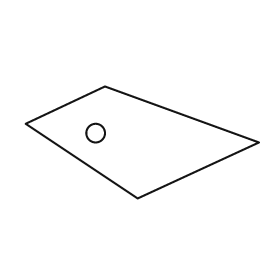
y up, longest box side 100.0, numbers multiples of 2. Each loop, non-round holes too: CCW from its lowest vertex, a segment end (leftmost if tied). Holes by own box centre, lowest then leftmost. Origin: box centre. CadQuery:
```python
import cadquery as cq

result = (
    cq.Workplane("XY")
    .moveTo(-2.0, -24.0)
    .lineTo(50.0, 0.0)
    .lineTo(-16.0, 24.0)
    .lineTo(-50.0, 8.0)
    .close()
    .moveTo(-20.0, 4.0)
    .circle(4.0)
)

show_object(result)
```